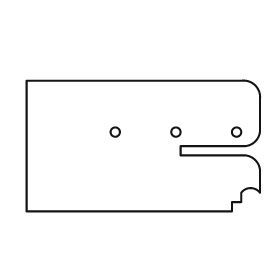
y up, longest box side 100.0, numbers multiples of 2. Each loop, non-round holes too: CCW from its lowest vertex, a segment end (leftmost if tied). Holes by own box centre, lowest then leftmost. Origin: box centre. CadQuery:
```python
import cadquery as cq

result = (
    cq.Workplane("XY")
    .moveTo(-50.0, -28.0)
    .lineTo(38.0, -28.0)
    .lineTo(38.0, -24.0)
    .lineTo(42.0, -24.0)
    .lineTo(42.0, -20.0)
    .threePointArc((46.0, -18.0), (50.0, -20.0))
    .lineTo(50.0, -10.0)
    .threePointArc((48.0, -6.0), (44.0, -4.0))
    .lineTo(16.0, -4.0)
    .lineTo(16.0, 0.0)
    .lineTo(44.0, 0.0)
    .threePointArc((48.0, 2.0), (50.0, 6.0))
    .lineTo(50.0, 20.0)
    .threePointArc((48.0, 26.0), (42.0, 28.0))
    .lineTo(-50.0, 28.0)
    .close()
    .moveTo(-12.0, 6.0)
    .circle(2.0)
    .moveTo(14.0, 6.0)
    .circle(2.0)
    .moveTo(40.0, 6.0)
    .circle(2.0)
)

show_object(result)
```